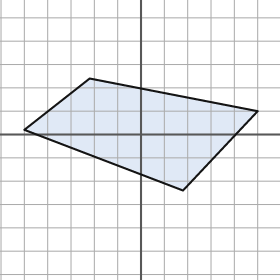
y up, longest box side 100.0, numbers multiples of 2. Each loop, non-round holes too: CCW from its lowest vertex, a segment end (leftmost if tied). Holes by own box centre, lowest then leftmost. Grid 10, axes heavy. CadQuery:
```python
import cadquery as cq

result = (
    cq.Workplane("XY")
    .moveTo(18.0, -24.0)
    .lineTo(50.0, 10.0)
    .lineTo(-22.0, 24.0)
    .lineTo(-50.0, 2.0)
    .close()
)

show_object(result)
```